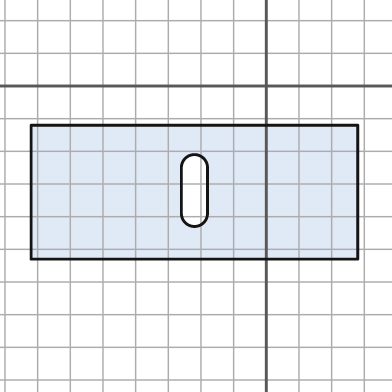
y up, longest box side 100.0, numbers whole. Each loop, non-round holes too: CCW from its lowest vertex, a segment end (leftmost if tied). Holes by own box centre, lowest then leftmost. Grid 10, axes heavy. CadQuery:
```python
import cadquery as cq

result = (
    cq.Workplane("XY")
    .moveTo(-72.0, -53.0)
    .lineTo(28.0, -53.0)
    .lineTo(28.0, -12.0)
    .lineTo(-72.0, -12.0)
    .close()
    .moveTo(-26.0, -39.0)
    .threePointArc((-22.0, -43.0), (-18.0, -39.0))
    .lineTo(-18.0, -25.0)
    .threePointArc((-22.0, -21.0), (-26.0, -25.0))
    .close()
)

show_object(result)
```